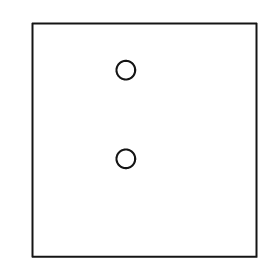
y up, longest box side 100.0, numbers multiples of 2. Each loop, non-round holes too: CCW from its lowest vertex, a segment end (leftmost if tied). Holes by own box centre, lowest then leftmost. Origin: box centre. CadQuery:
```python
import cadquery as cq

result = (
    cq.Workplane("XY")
    .moveTo(-48.0, -50.0)
    .lineTo(48.0, -50.0)
    .lineTo(48.0, 50.0)
    .lineTo(-48.0, 50.0)
    .close()
    .moveTo(-8.0, -8.0)
    .circle(4.0)
    .moveTo(-8.0, 30.0)
    .circle(4.0)
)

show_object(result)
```